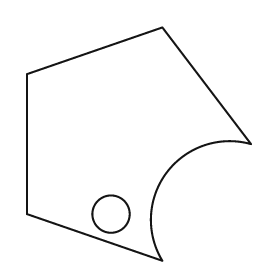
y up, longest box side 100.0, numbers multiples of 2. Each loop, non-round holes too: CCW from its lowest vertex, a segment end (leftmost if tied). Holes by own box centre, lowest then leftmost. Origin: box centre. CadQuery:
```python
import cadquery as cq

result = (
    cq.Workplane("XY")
    .moveTo(10.0, -50.0)
    .threePointArc((12.0, -12.0), (48.0, 0.0))
    .lineTo(10.0, 50.0)
    .lineTo(-48.0, 30.0)
    .lineTo(-48.0, -30.0)
    .close()
    .moveTo(-12.0, -30.0)
    .circle(8.0)
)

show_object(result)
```